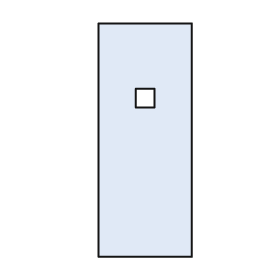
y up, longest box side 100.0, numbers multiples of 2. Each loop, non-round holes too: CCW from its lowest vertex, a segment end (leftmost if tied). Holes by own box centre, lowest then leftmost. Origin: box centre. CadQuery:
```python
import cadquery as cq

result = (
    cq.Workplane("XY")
    .moveTo(-20.0, -50.0)
    .lineTo(20.0, -50.0)
    .lineTo(20.0, 50.0)
    .lineTo(-20.0, 50.0)
    .close()
    .moveTo(-4.0, 14.0)
    .lineTo(4.0, 14.0)
    .lineTo(4.0, 22.0)
    .lineTo(-4.0, 22.0)
    .close()
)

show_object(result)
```